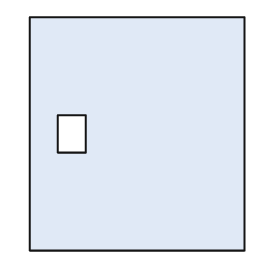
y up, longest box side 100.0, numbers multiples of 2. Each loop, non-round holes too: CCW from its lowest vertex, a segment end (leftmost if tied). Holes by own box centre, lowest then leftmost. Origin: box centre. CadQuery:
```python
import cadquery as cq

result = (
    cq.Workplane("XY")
    .moveTo(-46.0, -50.0)
    .lineTo(46.0, -50.0)
    .lineTo(46.0, 50.0)
    .lineTo(-46.0, 50.0)
    .close()
    .moveTo(-34.0, -8.0)
    .lineTo(-22.0, -8.0)
    .lineTo(-22.0, 8.0)
    .lineTo(-34.0, 8.0)
    .close()
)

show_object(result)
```